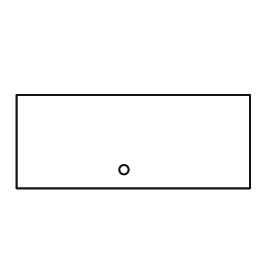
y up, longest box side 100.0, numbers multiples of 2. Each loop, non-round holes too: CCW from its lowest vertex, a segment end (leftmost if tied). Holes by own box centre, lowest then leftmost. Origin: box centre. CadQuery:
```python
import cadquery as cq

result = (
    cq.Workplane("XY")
    .moveTo(-50.0, -20.0)
    .lineTo(50.0, -20.0)
    .lineTo(50.0, 20.0)
    .lineTo(-50.0, 20.0)
    .close()
    .moveTo(-4.0, -12.0)
    .circle(2.0)
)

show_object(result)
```